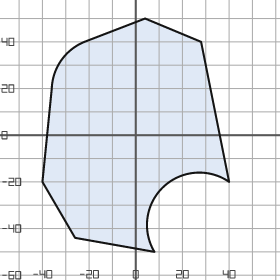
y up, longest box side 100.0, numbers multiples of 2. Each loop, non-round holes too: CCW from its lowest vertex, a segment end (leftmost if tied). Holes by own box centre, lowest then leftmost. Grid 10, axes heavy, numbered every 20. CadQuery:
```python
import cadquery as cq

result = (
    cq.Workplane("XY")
    .moveTo(8.0, -50.0)
    .threePointArc((12.0, -22.0), (40.0, -20.0))
    .lineTo(28.0, 40.0)
    .lineTo(4.0, 50.0)
    .lineTo(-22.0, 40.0)
    .threePointArc((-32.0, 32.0), (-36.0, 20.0))
    .lineTo(-40.0, -20.0)
    .lineTo(-26.0, -44.0)
    .close()
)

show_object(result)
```